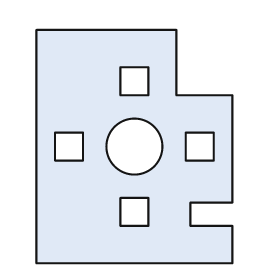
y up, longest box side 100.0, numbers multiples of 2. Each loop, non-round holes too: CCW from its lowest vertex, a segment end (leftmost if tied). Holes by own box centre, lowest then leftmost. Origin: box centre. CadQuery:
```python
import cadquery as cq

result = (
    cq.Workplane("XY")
    .moveTo(-42.0, -50.0)
    .lineTo(42.0, -50.0)
    .lineTo(42.0, -34.0)
    .lineTo(24.0, -34.0)
    .lineTo(24.0, -24.0)
    .lineTo(42.0, -24.0)
    .lineTo(42.0, 22.0)
    .lineTo(18.0, 22.0)
    .lineTo(18.0, 50.0)
    .lineTo(-42.0, 50.0)
    .close()
    .moveTo(-6.0, -34.0)
    .lineTo(6.0, -34.0)
    .lineTo(6.0, -22.0)
    .lineTo(-6.0, -22.0)
    .close()
    .moveTo(-34.0, -6.0)
    .lineTo(-22.0, -6.0)
    .lineTo(-22.0, 6.0)
    .lineTo(-34.0, 6.0)
    .close()
    .moveTo(0.0, 0.0)
    .circle(12.0)
    .moveTo(22.0, -6.0)
    .lineTo(34.0, -6.0)
    .lineTo(34.0, 6.0)
    .lineTo(22.0, 6.0)
    .close()
    .moveTo(-6.0, 22.0)
    .lineTo(6.0, 22.0)
    .lineTo(6.0, 34.0)
    .lineTo(-6.0, 34.0)
    .close()
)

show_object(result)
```